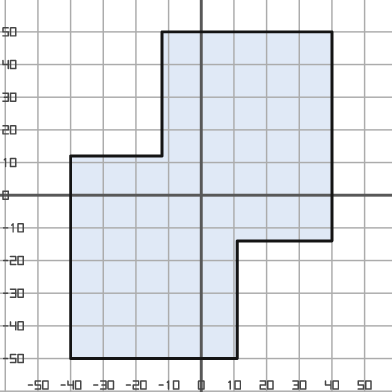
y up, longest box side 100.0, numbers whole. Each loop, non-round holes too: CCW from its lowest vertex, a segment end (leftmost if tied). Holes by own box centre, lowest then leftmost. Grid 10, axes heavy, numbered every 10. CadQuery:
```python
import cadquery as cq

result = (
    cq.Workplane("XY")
    .moveTo(-40.0, -50.0)
    .lineTo(11.0, -50.0)
    .lineTo(11.0, -14.0)
    .lineTo(40.0, -14.0)
    .lineTo(40.0, 50.0)
    .lineTo(-12.0, 50.0)
    .lineTo(-12.0, 12.0)
    .lineTo(-40.0, 12.0)
    .close()
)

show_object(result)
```